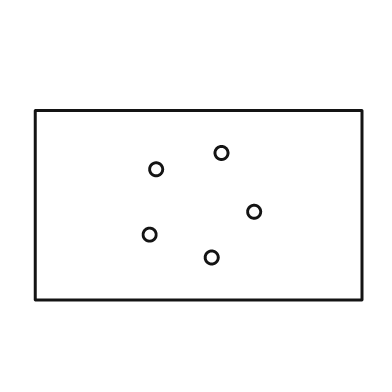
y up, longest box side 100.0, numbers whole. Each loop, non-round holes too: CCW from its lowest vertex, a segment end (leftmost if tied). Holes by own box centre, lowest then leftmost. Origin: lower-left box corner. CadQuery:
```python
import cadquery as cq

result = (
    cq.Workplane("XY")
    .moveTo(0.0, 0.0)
    .lineTo(100.0, 0.0)
    .lineTo(100.0, 58.0)
    .lineTo(0.0, 58.0)
    .close()
    .moveTo(54.0, 13.0)
    .circle(2.0)
    .moveTo(35.0, 20.0)
    .circle(2.0)
    .moveTo(67.0, 27.0)
    .circle(2.0)
    .moveTo(37.0, 40.0)
    .circle(2.0)
    .moveTo(57.0, 45.0)
    .circle(2.0)
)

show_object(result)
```